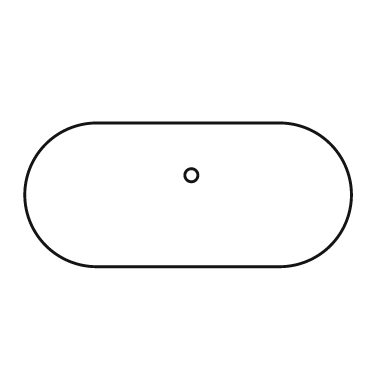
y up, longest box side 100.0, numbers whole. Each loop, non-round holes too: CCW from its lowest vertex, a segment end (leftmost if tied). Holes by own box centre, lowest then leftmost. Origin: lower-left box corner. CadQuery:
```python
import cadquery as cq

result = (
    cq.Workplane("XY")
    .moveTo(22.0, 0.0)
    .lineTo(78.0, 0.0)
    .threePointArc((100.0, 22.0), (78.0, 44.0))
    .lineTo(22.0, 44.0)
    .threePointArc((0.0, 22.0), (22.0, 0.0))
    .close()
    .moveTo(51.0, 28.0)
    .circle(2.0)
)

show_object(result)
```